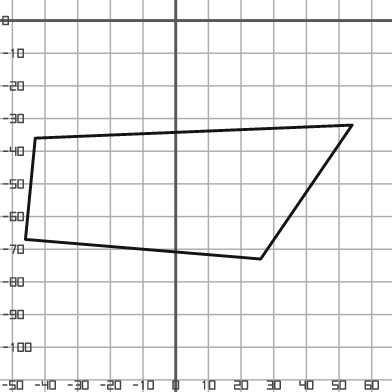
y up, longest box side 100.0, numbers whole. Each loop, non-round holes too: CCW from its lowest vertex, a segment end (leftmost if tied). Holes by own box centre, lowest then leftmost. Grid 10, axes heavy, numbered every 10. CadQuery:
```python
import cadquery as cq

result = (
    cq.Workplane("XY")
    .moveTo(26.0, -73.0)
    .lineTo(54.0, -32.0)
    .lineTo(-43.0, -36.0)
    .lineTo(-46.0, -67.0)
    .close()
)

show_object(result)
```